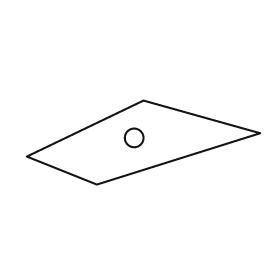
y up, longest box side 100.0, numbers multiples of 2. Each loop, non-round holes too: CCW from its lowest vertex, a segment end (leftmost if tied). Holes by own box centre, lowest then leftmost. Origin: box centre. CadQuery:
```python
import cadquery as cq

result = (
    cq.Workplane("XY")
    .moveTo(-20.0, -18.0)
    .lineTo(50.0, 4.0)
    .lineTo(0.0, 18.0)
    .lineTo(-50.0, -6.0)
    .close()
    .moveTo(-4.0, 2.0)
    .circle(4.0)
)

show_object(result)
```